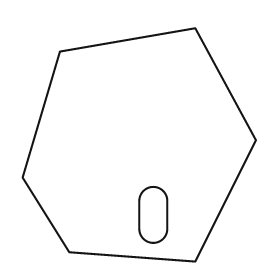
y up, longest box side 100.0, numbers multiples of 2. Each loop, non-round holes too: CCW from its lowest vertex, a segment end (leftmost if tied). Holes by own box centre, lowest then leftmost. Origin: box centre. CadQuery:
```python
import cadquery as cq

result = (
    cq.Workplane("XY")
    .moveTo(24.0, -50.0)
    .lineTo(50.0, 2.0)
    .lineTo(24.0, 50.0)
    .lineTo(-34.0, 40.0)
    .lineTo(-50.0, -14.0)
    .lineTo(-30.0, -46.0)
    .close()
    .moveTo(0.0, -36.0)
    .threePointArc((6.0, -42.0), (12.0, -36.0))
    .lineTo(12.0, -24.0)
    .threePointArc((6.0, -18.0), (0.0, -24.0))
    .close()
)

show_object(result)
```